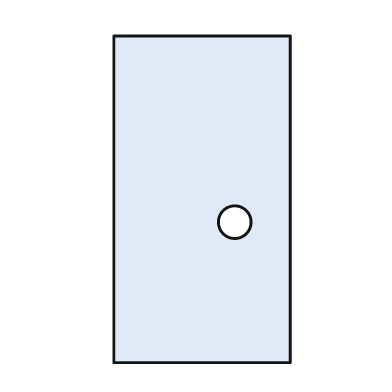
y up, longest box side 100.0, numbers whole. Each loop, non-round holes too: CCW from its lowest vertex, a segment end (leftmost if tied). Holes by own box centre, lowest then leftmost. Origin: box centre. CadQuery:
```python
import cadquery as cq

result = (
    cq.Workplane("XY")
    .moveTo(-27.0, -50.0)
    .lineTo(27.0, -50.0)
    .lineTo(27.0, 50.0)
    .lineTo(-27.0, 50.0)
    .close()
    .moveTo(10.0, -7.0)
    .circle(5.0)
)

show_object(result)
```